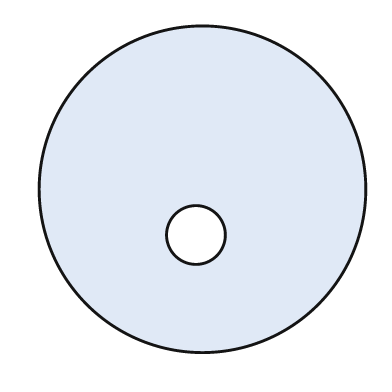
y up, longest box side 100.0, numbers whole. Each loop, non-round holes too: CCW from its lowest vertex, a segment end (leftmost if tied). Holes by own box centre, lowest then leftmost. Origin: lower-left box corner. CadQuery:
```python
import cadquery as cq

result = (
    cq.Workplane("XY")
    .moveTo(50.0, 50.0)
    .circle(50.0)
    .moveTo(48.0, 36.0)
    .circle(9.0)
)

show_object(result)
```